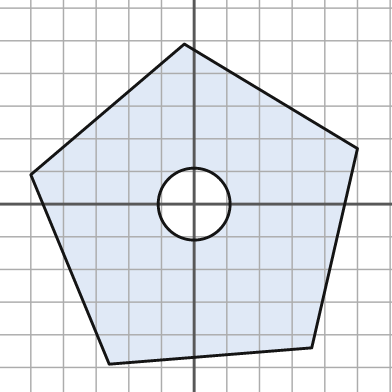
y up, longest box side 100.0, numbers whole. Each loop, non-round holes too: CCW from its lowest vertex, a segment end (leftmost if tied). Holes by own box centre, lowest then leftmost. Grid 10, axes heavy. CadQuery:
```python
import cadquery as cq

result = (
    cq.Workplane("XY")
    .moveTo(-26.0, -49.0)
    .lineTo(36.0, -44.0)
    .lineTo(50.0, 17.0)
    .lineTo(-3.0, 49.0)
    .lineTo(-50.0, 9.0)
    .close()
    .moveTo(0.0, 0.0)
    .circle(11.0)
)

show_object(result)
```